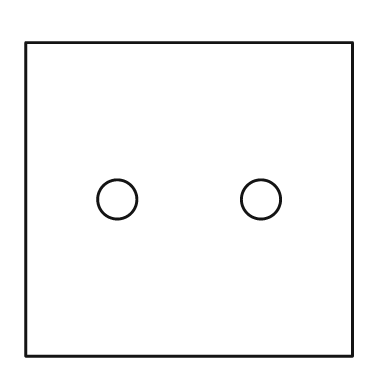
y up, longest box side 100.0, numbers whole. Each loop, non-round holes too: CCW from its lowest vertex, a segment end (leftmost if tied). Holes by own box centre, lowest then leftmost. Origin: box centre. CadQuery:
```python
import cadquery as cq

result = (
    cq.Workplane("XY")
    .moveTo(-50.0, -48.0)
    .lineTo(50.0, -48.0)
    .lineTo(50.0, 48.0)
    .lineTo(-50.0, 48.0)
    .close()
    .moveTo(-22.0, 0.0)
    .circle(6.0)
    .moveTo(22.0, 0.0)
    .circle(6.0)
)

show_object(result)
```